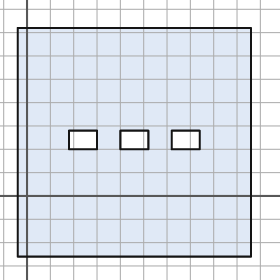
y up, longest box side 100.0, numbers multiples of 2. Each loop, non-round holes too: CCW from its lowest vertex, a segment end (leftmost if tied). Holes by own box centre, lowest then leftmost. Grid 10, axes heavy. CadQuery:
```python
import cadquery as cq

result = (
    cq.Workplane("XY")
    .moveTo(-4.0, -26.0)
    .lineTo(96.0, -26.0)
    .lineTo(96.0, 72.0)
    .lineTo(-4.0, 72.0)
    .close()
    .moveTo(18.0, 20.0)
    .lineTo(30.0, 20.0)
    .lineTo(30.0, 28.0)
    .lineTo(18.0, 28.0)
    .close()
    .moveTo(40.0, 20.0)
    .lineTo(52.0, 20.0)
    .lineTo(52.0, 28.0)
    .lineTo(40.0, 28.0)
    .close()
    .moveTo(62.0, 20.0)
    .lineTo(74.0, 20.0)
    .lineTo(74.0, 28.0)
    .lineTo(62.0, 28.0)
    .close()
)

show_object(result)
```